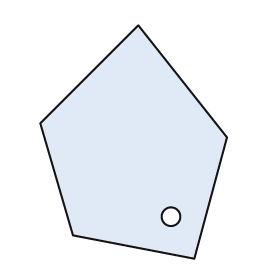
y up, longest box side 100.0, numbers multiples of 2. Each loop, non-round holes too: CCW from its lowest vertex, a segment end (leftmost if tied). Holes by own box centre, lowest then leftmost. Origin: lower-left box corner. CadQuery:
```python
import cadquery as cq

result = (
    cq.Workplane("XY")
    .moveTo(66.0, 0.0)
    .lineTo(80.0, 52.0)
    .lineTo(42.0, 100.0)
    .lineTo(0.0, 58.0)
    .lineTo(14.0, 10.0)
    .close()
    .moveTo(56.0, 18.0)
    .circle(4.0)
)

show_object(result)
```